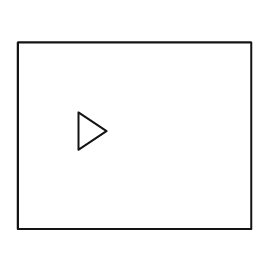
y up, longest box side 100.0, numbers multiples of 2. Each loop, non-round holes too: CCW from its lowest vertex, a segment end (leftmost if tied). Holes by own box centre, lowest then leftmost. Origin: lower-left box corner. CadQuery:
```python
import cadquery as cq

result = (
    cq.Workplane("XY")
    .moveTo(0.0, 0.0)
    .lineTo(100.0, 0.0)
    .lineTo(100.0, 80.0)
    .lineTo(0.0, 80.0)
    .close()
    .moveTo(26.0, 34.0)
    .lineTo(38.0, 42.0)
    .lineTo(26.0, 50.0)
    .close()
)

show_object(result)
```